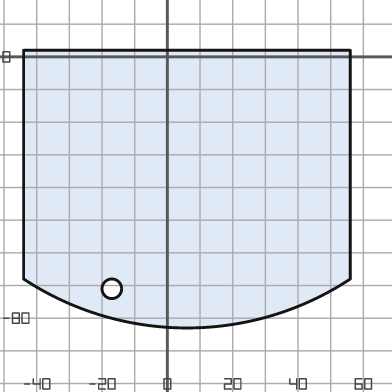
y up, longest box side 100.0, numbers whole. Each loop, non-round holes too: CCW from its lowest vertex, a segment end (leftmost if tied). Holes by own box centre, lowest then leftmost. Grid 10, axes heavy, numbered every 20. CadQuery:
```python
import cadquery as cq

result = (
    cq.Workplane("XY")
    .moveTo(-44.0, -68.0)
    .threePointArc((6.0, -83.0), (56.0, -68.0))
    .lineTo(56.0, 2.0)
    .lineTo(-44.0, 2.0)
    .close()
    .moveTo(-17.0, -71.0)
    .circle(3.0)
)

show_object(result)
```